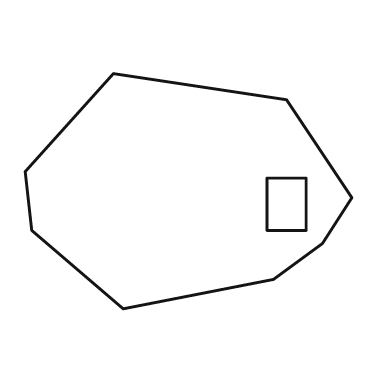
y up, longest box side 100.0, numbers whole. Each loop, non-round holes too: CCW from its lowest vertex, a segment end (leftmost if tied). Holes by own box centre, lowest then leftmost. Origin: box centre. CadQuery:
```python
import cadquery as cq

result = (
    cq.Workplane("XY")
    .moveTo(-20.0, -36.0)
    .lineTo(26.0, -27.0)
    .lineTo(41.0, -16.0)
    .lineTo(50.0, -2.0)
    .lineTo(30.0, 28.0)
    .lineTo(-23.0, 36.0)
    .lineTo(-50.0, 6.0)
    .lineTo(-48.0, -12.0)
    .close()
    .moveTo(24.0, -12.0)
    .lineTo(36.0, -12.0)
    .lineTo(36.0, 4.0)
    .lineTo(24.0, 4.0)
    .close()
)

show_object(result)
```